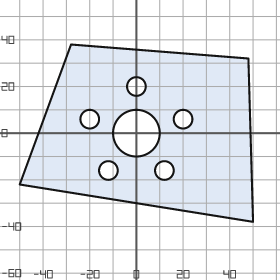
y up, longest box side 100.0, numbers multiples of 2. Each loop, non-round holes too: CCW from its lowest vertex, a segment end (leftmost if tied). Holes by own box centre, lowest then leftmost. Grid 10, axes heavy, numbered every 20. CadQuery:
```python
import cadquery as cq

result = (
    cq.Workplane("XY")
    .moveTo(50.0, -38.0)
    .lineTo(48.0, 32.0)
    .lineTo(-28.0, 38.0)
    .lineTo(-50.0, -22.0)
    .close()
    .moveTo(-12.0, -16.0)
    .circle(4.0)
    .moveTo(12.0, -16.0)
    .circle(4.0)
    .moveTo(0.0, 0.0)
    .circle(10.0)
    .moveTo(-20.0, 6.0)
    .circle(4.0)
    .moveTo(20.0, 6.0)
    .circle(4.0)
    .moveTo(0.0, 20.0)
    .circle(4.0)
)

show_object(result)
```